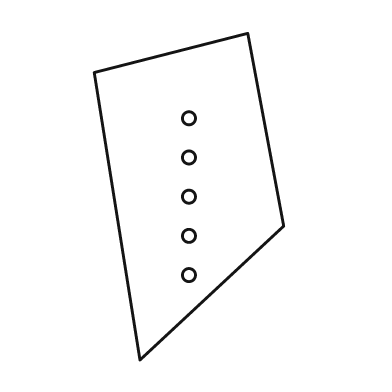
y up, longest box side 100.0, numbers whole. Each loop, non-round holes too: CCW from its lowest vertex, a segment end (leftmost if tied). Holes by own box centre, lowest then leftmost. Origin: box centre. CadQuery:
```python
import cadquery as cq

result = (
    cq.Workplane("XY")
    .moveTo(-15.0, -50.0)
    .lineTo(29.0, -9.0)
    .lineTo(18.0, 50.0)
    .lineTo(-29.0, 38.0)
    .close()
    .moveTo(0.0, -24.0)
    .circle(2.0)
    .moveTo(0.0, -12.0)
    .circle(2.0)
    .moveTo(0.0, 0.0)
    .circle(2.0)
    .moveTo(0.0, 12.0)
    .circle(2.0)
    .moveTo(0.0, 24.0)
    .circle(2.0)
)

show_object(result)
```